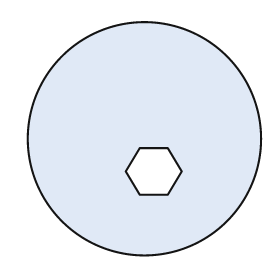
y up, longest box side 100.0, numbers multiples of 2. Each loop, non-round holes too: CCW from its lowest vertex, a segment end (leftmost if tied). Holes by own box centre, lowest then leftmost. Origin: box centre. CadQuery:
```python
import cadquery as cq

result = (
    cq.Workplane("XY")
    .moveTo(0.0, 0.0)
    .circle(50.0)
    .moveTo(-2.0, -24.0)
    .lineTo(10.0, -24.0)
    .lineTo(16.0, -14.0)
    .lineTo(10.0, -4.0)
    .lineTo(-2.0, -4.0)
    .lineTo(-8.0, -14.0)
    .close()
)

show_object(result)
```